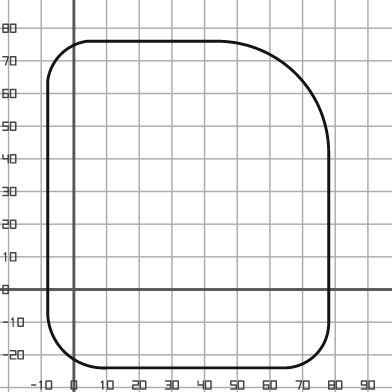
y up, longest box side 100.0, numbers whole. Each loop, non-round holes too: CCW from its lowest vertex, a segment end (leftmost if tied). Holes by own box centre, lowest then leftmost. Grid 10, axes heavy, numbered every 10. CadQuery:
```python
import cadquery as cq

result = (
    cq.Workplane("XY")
    .moveTo(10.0, -24.0)
    .lineTo(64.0, -24.0)
    .threePointArc((74.0, -20.0), (78.0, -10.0))
    .lineTo(78.0, 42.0)
    .threePointArc((68.0, 66.0), (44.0, 76.0))
    .lineTo(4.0, 76.0)
    .threePointArc((-4.0, 72.0), (-8.0, 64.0))
    .lineTo(-8.0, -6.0)
    .threePointArc((-3.0, -19.0), (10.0, -24.0))
    .close()
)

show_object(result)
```